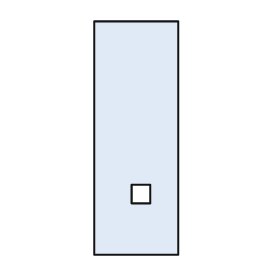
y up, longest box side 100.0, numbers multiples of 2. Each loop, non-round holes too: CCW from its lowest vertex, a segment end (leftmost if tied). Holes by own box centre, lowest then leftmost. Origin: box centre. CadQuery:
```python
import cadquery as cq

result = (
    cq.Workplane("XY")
    .moveTo(-18.0, -50.0)
    .lineTo(18.0, -50.0)
    .lineTo(18.0, 50.0)
    .lineTo(-18.0, 50.0)
    .close()
    .moveTo(-2.0, -28.0)
    .lineTo(6.0, -28.0)
    .lineTo(6.0, -20.0)
    .lineTo(-2.0, -20.0)
    .close()
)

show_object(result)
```